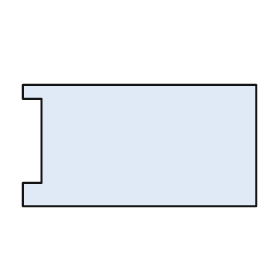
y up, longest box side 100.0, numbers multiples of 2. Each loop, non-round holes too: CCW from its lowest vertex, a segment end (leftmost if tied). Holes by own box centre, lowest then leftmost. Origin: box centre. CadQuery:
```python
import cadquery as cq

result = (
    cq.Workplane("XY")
    .moveTo(-50.0, -26.0)
    .lineTo(50.0, -26.0)
    .lineTo(50.0, 26.0)
    .lineTo(-50.0, 26.0)
    .lineTo(-50.0, 20.0)
    .lineTo(-42.0, 20.0)
    .lineTo(-42.0, -16.0)
    .lineTo(-50.0, -16.0)
    .close()
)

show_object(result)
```